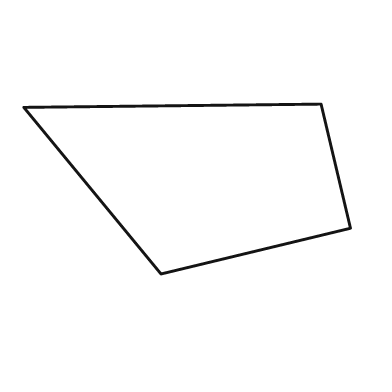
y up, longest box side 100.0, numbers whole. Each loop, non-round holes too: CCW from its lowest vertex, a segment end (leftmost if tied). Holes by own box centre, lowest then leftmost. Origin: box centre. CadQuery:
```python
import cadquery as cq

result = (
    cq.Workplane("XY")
    .moveTo(-8.0, -26.0)
    .lineTo(50.0, -12.0)
    .lineTo(41.0, 26.0)
    .lineTo(-50.0, 25.0)
    .close()
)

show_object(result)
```